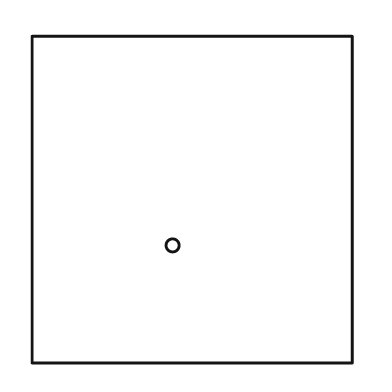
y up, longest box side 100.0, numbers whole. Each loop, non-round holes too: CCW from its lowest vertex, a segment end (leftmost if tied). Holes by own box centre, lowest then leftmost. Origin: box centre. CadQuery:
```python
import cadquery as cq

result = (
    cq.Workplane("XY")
    .moveTo(-49.0, -50.0)
    .lineTo(49.0, -50.0)
    .lineTo(49.0, 50.0)
    .lineTo(-49.0, 50.0)
    .close()
    .moveTo(-6.0, -14.0)
    .circle(2.0)
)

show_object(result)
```